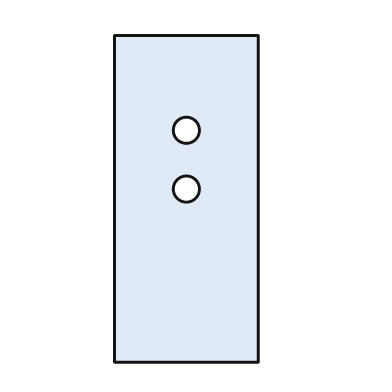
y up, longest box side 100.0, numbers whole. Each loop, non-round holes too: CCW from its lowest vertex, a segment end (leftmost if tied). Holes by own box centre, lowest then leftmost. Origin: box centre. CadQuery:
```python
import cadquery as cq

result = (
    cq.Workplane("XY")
    .moveTo(-22.0, -50.0)
    .lineTo(22.0, -50.0)
    .lineTo(22.0, 50.0)
    .lineTo(-22.0, 50.0)
    .close()
    .moveTo(0.0, 3.0)
    .circle(4.0)
    .moveTo(0.0, 21.0)
    .circle(4.0)
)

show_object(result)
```